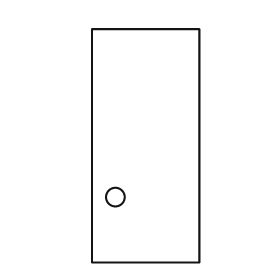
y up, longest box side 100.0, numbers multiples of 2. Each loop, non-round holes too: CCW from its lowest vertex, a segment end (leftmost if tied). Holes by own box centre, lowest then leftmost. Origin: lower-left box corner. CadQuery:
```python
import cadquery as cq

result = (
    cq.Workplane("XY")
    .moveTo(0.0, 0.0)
    .lineTo(46.0, 0.0)
    .lineTo(46.0, 100.0)
    .lineTo(0.0, 100.0)
    .close()
    .moveTo(10.0, 28.0)
    .circle(4.0)
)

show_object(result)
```